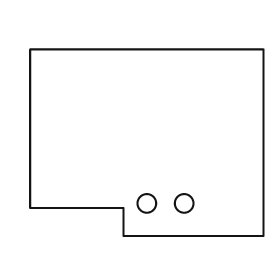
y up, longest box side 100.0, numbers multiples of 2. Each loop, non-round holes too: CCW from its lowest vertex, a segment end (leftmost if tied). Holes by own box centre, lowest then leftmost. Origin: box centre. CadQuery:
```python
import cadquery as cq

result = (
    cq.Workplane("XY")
    .moveTo(-10.0, -40.0)
    .lineTo(50.0, -40.0)
    .lineTo(50.0, 40.0)
    .lineTo(-50.0, 40.0)
    .lineTo(-50.0, -28.0)
    .lineTo(-10.0, -28.0)
    .close()
    .moveTo(0.0, -26.0)
    .circle(4.0)
    .moveTo(16.0, -26.0)
    .circle(4.0)
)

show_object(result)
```